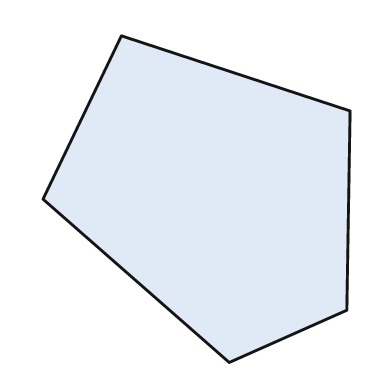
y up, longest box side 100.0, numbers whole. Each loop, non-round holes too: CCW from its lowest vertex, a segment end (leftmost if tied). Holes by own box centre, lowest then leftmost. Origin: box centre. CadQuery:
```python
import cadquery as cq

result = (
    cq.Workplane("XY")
    .moveTo(10.0, -50.0)
    .lineTo(46.0, -34.0)
    .lineTo(47.0, 27.0)
    .lineTo(-23.0, 50.0)
    .lineTo(-47.0, 0.0)
    .close()
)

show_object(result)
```